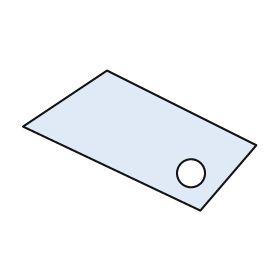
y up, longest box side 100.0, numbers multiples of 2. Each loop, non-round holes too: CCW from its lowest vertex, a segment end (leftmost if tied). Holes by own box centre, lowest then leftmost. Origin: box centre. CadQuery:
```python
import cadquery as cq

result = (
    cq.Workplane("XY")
    .moveTo(26.0, -30.0)
    .lineTo(50.0, -2.0)
    .lineTo(-14.0, 30.0)
    .lineTo(-50.0, 6.0)
    .close()
    .moveTo(22.0, -14.0)
    .circle(6.0)
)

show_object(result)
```